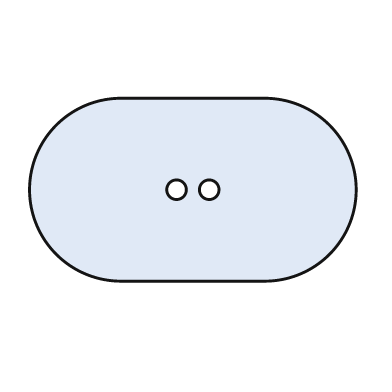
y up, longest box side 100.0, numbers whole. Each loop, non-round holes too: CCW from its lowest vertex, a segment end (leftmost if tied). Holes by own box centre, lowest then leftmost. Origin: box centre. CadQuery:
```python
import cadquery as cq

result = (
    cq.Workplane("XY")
    .moveTo(-22.0, -28.0)
    .lineTo(22.0, -28.0)
    .threePointArc((50.0, 0.0), (22.0, 28.0))
    .lineTo(-22.0, 28.0)
    .threePointArc((-50.0, 0.0), (-22.0, -28.0))
    .close()
    .moveTo(-5.0, 0.0)
    .circle(3.0)
    .moveTo(5.0, 0.0)
    .circle(3.0)
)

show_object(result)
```